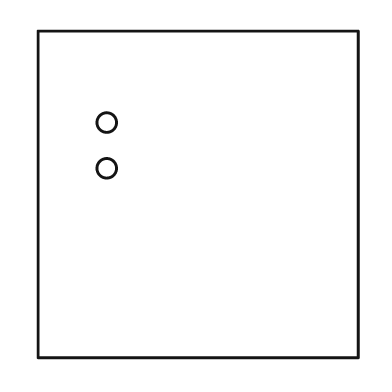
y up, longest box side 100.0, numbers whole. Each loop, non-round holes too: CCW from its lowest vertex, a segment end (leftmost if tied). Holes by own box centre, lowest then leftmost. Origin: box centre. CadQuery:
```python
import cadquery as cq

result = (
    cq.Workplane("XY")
    .moveTo(-49.0, -50.0)
    .lineTo(49.0, -50.0)
    .lineTo(49.0, 50.0)
    .lineTo(-49.0, 50.0)
    .close()
    .moveTo(-28.0, 8.0)
    .circle(3.0)
    .moveTo(-28.0, 22.0)
    .circle(3.0)
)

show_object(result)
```